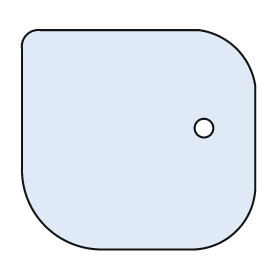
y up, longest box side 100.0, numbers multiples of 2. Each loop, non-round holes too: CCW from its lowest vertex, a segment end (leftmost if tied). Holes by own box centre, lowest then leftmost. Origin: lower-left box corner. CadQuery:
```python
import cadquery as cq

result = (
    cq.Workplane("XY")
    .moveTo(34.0, 0.0)
    .lineTo(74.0, 0.0)
    .threePointArc((92.0, 8.0), (100.0, 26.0))
    .lineTo(100.0, 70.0)
    .threePointArc((92.0, 86.0), (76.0, 94.0))
    .lineTo(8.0, 94.0)
    .threePointArc((2.0, 92.0), (0.0, 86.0))
    .lineTo(0.0, 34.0)
    .threePointArc((10.0, 10.0), (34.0, 0.0))
    .close()
    .moveTo(78.0, 52.0)
    .circle(4.0)
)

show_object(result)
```